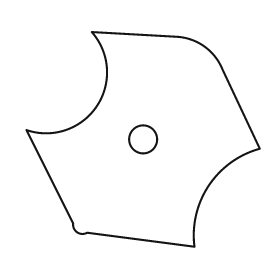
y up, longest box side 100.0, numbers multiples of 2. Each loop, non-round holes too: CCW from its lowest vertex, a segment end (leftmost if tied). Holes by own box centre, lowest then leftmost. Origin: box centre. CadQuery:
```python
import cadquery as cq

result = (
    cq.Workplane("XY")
    .moveTo(22.0, -46.0)
    .threePointArc((28.0, -20.0), (50.0, -4.0))
    .lineTo(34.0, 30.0)
    .threePointArc((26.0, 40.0), (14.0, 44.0))
    .lineTo(-22.0, 46.0)
    .threePointArc((-20.0, 14.0), (-50.0, 4.0))
    .lineTo(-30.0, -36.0)
    .threePointArc((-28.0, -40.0), (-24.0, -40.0))
    .close()
    .moveTo(0.0, 0.0)
    .circle(6.0)
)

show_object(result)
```